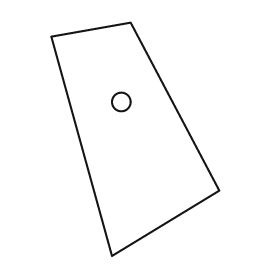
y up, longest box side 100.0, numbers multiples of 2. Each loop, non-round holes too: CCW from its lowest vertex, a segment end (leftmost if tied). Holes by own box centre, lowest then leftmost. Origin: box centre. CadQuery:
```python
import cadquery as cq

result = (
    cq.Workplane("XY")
    .moveTo(-10.0, -50.0)
    .lineTo(36.0, -22.0)
    .lineTo(-2.0, 50.0)
    .lineTo(-36.0, 44.0)
    .close()
    .moveTo(-6.0, 16.0)
    .circle(4.0)
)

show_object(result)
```